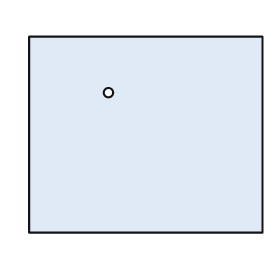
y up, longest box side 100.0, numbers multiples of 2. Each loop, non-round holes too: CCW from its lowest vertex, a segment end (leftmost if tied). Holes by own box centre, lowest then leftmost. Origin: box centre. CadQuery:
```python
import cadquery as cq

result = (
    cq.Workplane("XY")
    .moveTo(-50.0, -42.0)
    .lineTo(50.0, -42.0)
    .lineTo(50.0, 42.0)
    .lineTo(-50.0, 42.0)
    .close()
    .moveTo(-16.0, 18.0)
    .circle(2.0)
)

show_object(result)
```